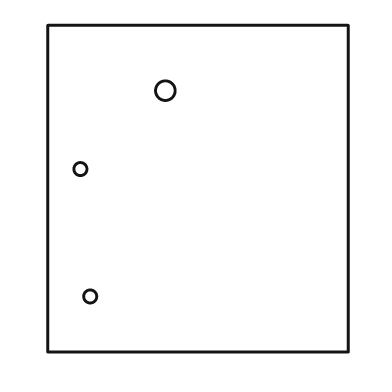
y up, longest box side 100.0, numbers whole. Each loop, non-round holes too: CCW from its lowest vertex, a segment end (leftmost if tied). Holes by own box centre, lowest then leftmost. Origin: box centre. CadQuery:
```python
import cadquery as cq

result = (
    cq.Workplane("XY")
    .moveTo(-46.0, -50.0)
    .lineTo(46.0, -50.0)
    .lineTo(46.0, 50.0)
    .lineTo(-46.0, 50.0)
    .close()
    .moveTo(-33.0, -33.0)
    .circle(2.0)
    .moveTo(-36.0, 6.0)
    .circle(2.0)
    .moveTo(-10.0, 30.0)
    .circle(3.0)
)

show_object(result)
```